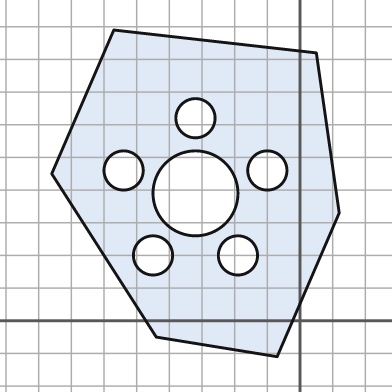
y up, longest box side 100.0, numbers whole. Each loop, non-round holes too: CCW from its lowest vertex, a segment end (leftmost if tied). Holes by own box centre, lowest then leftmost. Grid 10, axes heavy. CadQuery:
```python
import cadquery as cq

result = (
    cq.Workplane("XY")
    .moveTo(-7.0, -11.0)
    .lineTo(12.0, 33.0)
    .lineTo(5.0, 82.0)
    .lineTo(-57.0, 89.0)
    .lineTo(-76.0, 45.0)
    .lineTo(-44.0, -5.0)
    .close()
    .moveTo(-45.0, 20.0)
    .circle(6.0)
    .moveTo(-19.0, 20.0)
    .circle(6.0)
    .moveTo(-32.0, 39.0)
    .circle(13.0)
    .moveTo(-54.0, 46.0)
    .circle(6.0)
    .moveTo(-10.0, 46.0)
    .circle(6.0)
    .moveTo(-32.0, 62.0)
    .circle(6.0)
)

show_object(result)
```